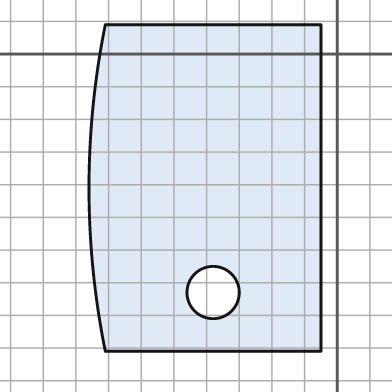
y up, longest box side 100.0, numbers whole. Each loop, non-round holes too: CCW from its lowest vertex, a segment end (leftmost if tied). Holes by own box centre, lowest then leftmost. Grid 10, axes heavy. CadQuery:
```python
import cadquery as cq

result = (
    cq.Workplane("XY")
    .moveTo(-71.0, -91.0)
    .lineTo(-5.0, -91.0)
    .lineTo(-5.0, 9.0)
    .lineTo(-71.0, 9.0)
    .threePointArc((-76.0, -41.0), (-71.0, -91.0))
    .close()
    .moveTo(-38.0, -73.0)
    .circle(8.0)
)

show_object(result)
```